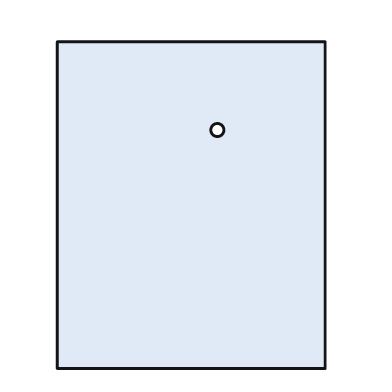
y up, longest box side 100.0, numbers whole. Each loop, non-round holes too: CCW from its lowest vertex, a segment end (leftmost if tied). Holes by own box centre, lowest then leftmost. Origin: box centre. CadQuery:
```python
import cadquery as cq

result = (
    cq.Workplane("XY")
    .moveTo(-41.0, -50.0)
    .lineTo(41.0, -50.0)
    .lineTo(41.0, 50.0)
    .lineTo(-41.0, 50.0)
    .close()
    .moveTo(8.0, 23.0)
    .circle(2.0)
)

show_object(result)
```